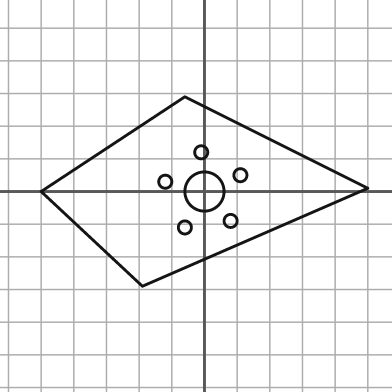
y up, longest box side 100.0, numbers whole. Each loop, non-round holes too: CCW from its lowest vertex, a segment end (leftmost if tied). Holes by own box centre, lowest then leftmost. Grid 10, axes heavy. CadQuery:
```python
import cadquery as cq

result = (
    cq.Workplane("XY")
    .moveTo(-19.0, -29.0)
    .lineTo(50.0, 1.0)
    .lineTo(-6.0, 29.0)
    .lineTo(-50.0, 0.0)
    .close()
    .moveTo(-6.0, -11.0)
    .circle(2.0)
    .moveTo(8.0, -9.0)
    .circle(2.0)
    .moveTo(0.0, 0.0)
    .circle(6.0)
    .moveTo(-12.0, 3.0)
    .circle(2.0)
    .moveTo(11.0, 5.0)
    .circle(2.0)
    .moveTo(-1.0, 12.0)
    .circle(2.0)
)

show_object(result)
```